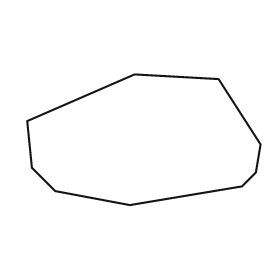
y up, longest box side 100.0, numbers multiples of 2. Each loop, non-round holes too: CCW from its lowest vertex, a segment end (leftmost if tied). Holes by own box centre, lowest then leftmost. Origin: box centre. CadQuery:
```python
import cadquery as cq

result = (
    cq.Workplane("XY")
    .moveTo(-6.0, -28.0)
    .lineTo(42.0, -20.0)
    .lineTo(48.0, -14.0)
    .lineTo(50.0, -2.0)
    .lineTo(32.0, 26.0)
    .lineTo(-4.0, 28.0)
    .lineTo(-50.0, 8.0)
    .lineTo(-48.0, -12.0)
    .lineTo(-38.0, -22.0)
    .close()
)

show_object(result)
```